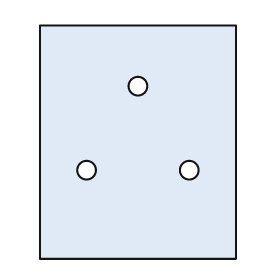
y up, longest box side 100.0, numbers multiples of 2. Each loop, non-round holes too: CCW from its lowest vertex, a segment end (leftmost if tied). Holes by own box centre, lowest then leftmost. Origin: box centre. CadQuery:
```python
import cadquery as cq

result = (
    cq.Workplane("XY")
    .moveTo(-42.0, -50.0)
    .lineTo(42.0, -50.0)
    .lineTo(42.0, 50.0)
    .lineTo(-42.0, 50.0)
    .close()
    .moveTo(-22.0, -12.0)
    .circle(4.0)
    .moveTo(22.0, -12.0)
    .circle(4.0)
    .moveTo(0.0, 24.0)
    .circle(4.0)
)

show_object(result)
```